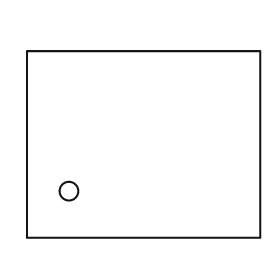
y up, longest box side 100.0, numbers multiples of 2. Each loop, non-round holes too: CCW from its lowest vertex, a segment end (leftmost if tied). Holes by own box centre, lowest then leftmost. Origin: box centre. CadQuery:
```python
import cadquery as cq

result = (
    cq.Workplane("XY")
    .moveTo(-50.0, -40.0)
    .lineTo(50.0, -40.0)
    .lineTo(50.0, 40.0)
    .lineTo(-50.0, 40.0)
    .close()
    .moveTo(-32.0, -20.0)
    .circle(4.0)
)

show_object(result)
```